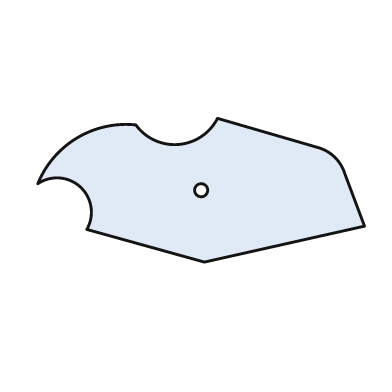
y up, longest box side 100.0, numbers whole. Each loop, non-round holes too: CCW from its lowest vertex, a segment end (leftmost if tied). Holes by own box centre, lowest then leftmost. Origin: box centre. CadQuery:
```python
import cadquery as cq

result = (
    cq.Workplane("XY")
    .moveTo(1.0, -22.0)
    .lineTo(50.0, -11.0)
    .lineTo(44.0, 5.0)
    .threePointArc((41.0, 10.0), (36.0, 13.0))
    .lineTo(5.0, 22.0)
    .threePointArc((-7.0, 14.0), (-20.0, 20.0))
    .threePointArc((-38.0, 16.0), (-50.0, 2.0))
    .threePointArc((-37.0, 1.0), (-35.0, -12.0))
    .close()
    .moveTo(0.0, 0.0)
    .circle(2.0)
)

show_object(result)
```